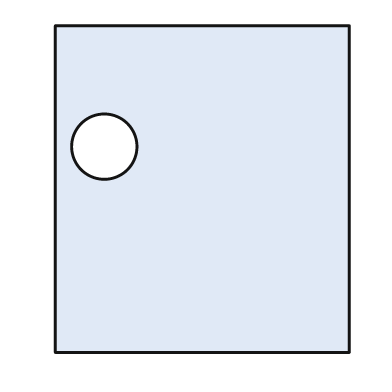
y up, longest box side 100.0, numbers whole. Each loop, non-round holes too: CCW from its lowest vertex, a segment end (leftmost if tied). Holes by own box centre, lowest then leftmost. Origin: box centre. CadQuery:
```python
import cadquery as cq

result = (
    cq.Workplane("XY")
    .moveTo(-45.0, -50.0)
    .lineTo(45.0, -50.0)
    .lineTo(45.0, 50.0)
    .lineTo(-45.0, 50.0)
    .close()
    .moveTo(-30.0, 13.0)
    .circle(10.0)
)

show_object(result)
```